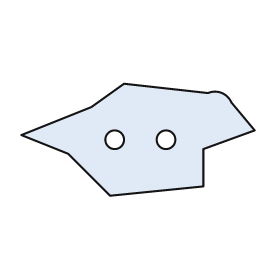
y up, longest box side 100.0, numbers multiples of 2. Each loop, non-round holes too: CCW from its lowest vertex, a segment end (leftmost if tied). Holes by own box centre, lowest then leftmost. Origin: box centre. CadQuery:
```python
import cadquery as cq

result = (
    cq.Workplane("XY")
    .moveTo(-12.0, -24.0)
    .lineTo(28.0, -20.0)
    .lineTo(28.0, -4.0)
    .lineTo(50.0, 4.0)
    .lineTo(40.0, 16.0)
    .threePointArc((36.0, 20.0), (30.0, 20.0))
    .lineTo(-6.0, 24.0)
    .lineTo(-20.0, 14.0)
    .lineTo(-50.0, 2.0)
    .lineTo(-30.0, -6.0)
    .close()
    .moveTo(-10.0, 0.0)
    .circle(4.0)
    .moveTo(12.0, 0.0)
    .circle(4.0)
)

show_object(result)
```